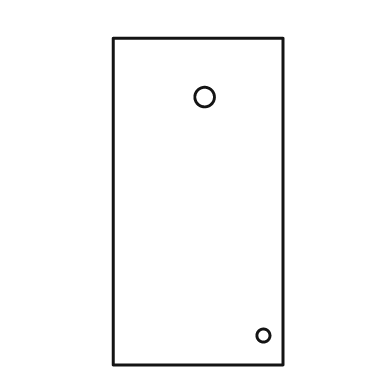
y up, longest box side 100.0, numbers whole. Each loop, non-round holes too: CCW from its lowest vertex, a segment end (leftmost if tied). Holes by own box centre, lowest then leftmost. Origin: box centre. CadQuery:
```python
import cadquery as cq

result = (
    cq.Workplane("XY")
    .moveTo(-26.0, -50.0)
    .lineTo(26.0, -50.0)
    .lineTo(26.0, 50.0)
    .lineTo(-26.0, 50.0)
    .close()
    .moveTo(20.0, -41.0)
    .circle(2.0)
    .moveTo(2.0, 32.0)
    .circle(3.0)
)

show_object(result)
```